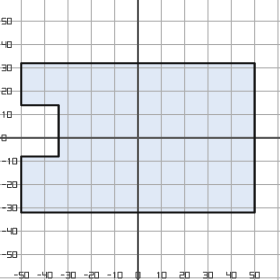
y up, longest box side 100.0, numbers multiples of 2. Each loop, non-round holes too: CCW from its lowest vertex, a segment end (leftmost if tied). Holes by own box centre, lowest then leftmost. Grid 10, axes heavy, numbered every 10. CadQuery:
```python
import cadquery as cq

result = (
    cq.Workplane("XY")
    .moveTo(-50.0, -32.0)
    .lineTo(50.0, -32.0)
    .lineTo(50.0, 32.0)
    .lineTo(-50.0, 32.0)
    .lineTo(-50.0, 14.0)
    .lineTo(-34.0, 14.0)
    .lineTo(-34.0, -8.0)
    .lineTo(-50.0, -8.0)
    .close()
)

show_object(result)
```